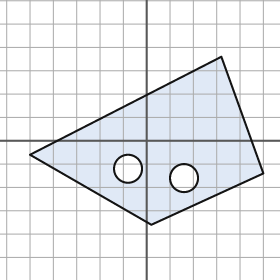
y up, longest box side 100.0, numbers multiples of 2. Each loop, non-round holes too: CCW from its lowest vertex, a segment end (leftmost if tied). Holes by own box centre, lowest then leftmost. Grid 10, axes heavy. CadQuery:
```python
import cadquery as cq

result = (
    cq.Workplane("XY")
    .moveTo(2.0, -36.0)
    .lineTo(50.0, -14.0)
    .lineTo(32.0, 36.0)
    .lineTo(-50.0, -6.0)
    .close()
    .moveTo(16.0, -16.0)
    .circle(6.0)
    .moveTo(-8.0, -12.0)
    .circle(6.0)
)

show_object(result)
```